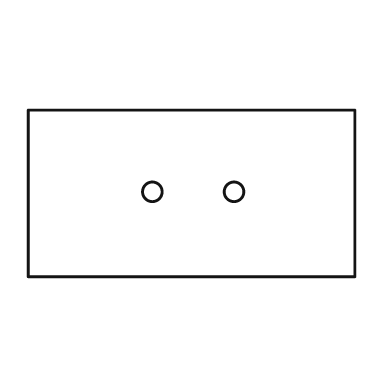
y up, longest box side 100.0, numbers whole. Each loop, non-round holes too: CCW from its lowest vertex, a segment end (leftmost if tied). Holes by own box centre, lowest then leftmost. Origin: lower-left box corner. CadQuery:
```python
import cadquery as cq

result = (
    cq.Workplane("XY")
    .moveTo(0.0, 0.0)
    .lineTo(100.0, 0.0)
    .lineTo(100.0, 51.0)
    .lineTo(0.0, 51.0)
    .close()
    .moveTo(38.0, 26.0)
    .circle(3.0)
    .moveTo(63.0, 26.0)
    .circle(3.0)
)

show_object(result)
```